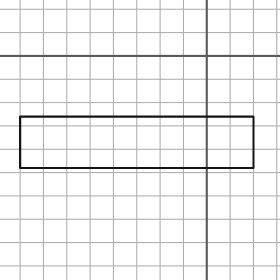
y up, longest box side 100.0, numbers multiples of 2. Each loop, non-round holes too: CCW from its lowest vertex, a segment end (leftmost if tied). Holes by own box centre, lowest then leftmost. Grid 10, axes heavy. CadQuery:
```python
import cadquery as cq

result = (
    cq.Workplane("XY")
    .moveTo(-80.0, -48.0)
    .lineTo(20.0, -48.0)
    .lineTo(20.0, -26.0)
    .lineTo(-80.0, -26.0)
    .close()
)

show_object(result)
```